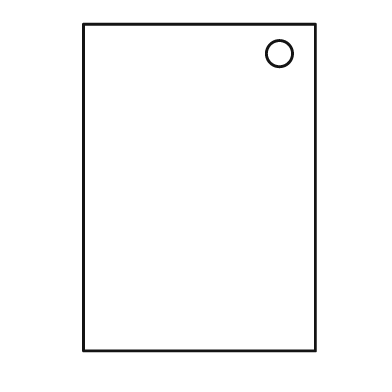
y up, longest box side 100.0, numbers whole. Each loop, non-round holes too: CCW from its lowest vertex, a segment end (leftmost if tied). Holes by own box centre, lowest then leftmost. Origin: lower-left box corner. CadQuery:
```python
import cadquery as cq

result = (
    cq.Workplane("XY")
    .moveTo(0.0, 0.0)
    .lineTo(71.0, 0.0)
    .lineTo(71.0, 100.0)
    .lineTo(0.0, 100.0)
    .close()
    .moveTo(60.0, 91.0)
    .circle(4.0)
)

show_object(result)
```